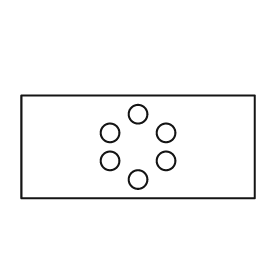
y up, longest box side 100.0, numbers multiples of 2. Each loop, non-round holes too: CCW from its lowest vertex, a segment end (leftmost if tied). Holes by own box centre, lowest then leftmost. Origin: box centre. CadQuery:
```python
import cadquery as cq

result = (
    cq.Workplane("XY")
    .moveTo(-50.0, -22.0)
    .lineTo(50.0, -22.0)
    .lineTo(50.0, 22.0)
    .lineTo(-50.0, 22.0)
    .close()
    .moveTo(0.0, -14.0)
    .circle(4.0)
    .moveTo(-12.0, -6.0)
    .circle(4.0)
    .moveTo(12.0, -6.0)
    .circle(4.0)
    .moveTo(-12.0, 6.0)
    .circle(4.0)
    .moveTo(12.0, 6.0)
    .circle(4.0)
    .moveTo(0.0, 14.0)
    .circle(4.0)
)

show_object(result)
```